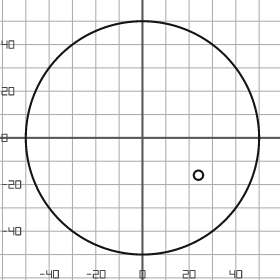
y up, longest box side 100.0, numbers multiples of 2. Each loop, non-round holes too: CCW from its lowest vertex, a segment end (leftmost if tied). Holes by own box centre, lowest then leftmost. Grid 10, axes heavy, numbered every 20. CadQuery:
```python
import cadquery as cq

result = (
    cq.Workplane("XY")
    .moveTo(0.0, 0.0)
    .circle(50.0)
    .moveTo(24.0, -16.0)
    .circle(2.0)
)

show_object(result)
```